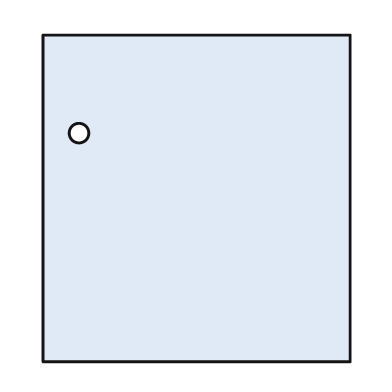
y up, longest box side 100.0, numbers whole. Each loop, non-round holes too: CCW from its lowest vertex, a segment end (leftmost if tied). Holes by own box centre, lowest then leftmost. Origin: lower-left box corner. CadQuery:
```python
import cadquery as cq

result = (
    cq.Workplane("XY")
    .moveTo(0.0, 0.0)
    .lineTo(94.0, 0.0)
    .lineTo(94.0, 100.0)
    .lineTo(0.0, 100.0)
    .close()
    .moveTo(11.0, 70.0)
    .circle(3.0)
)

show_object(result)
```